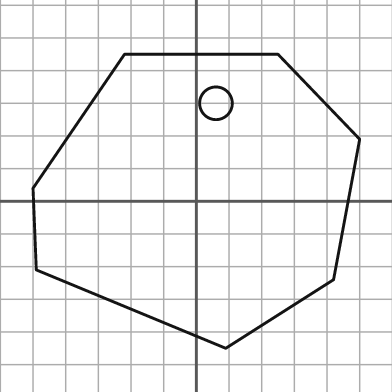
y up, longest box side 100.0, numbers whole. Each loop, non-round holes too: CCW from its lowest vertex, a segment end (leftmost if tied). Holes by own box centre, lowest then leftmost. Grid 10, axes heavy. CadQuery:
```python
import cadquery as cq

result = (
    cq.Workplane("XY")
    .moveTo(9.0, -45.0)
    .lineTo(42.0, -24.0)
    .lineTo(50.0, 19.0)
    .lineTo(25.0, 45.0)
    .lineTo(-22.0, 45.0)
    .lineTo(-50.0, 4.0)
    .lineTo(-49.0, -21.0)
    .close()
    .moveTo(6.0, 30.0)
    .circle(5.0)
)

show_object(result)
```